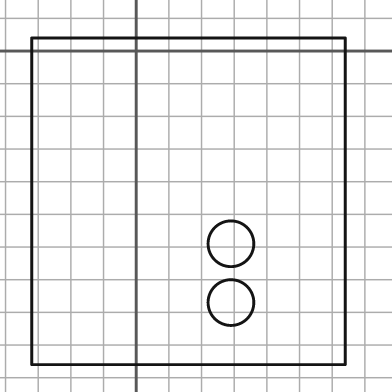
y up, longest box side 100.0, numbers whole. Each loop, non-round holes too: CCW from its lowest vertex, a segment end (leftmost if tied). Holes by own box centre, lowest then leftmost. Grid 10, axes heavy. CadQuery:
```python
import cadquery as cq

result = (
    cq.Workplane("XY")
    .moveTo(-32.0, -96.0)
    .lineTo(64.0, -96.0)
    .lineTo(64.0, 4.0)
    .lineTo(-32.0, 4.0)
    .close()
    .moveTo(29.0, -77.0)
    .circle(7.0)
    .moveTo(29.0, -59.0)
    .circle(7.0)
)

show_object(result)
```